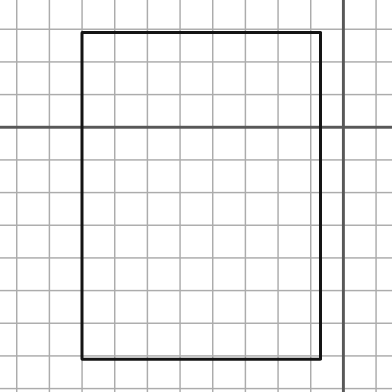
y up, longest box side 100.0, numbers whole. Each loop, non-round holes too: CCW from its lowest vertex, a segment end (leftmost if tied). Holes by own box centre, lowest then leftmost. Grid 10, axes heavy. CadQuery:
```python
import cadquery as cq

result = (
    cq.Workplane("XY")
    .moveTo(-80.0, -71.0)
    .lineTo(-7.0, -71.0)
    .lineTo(-7.0, 29.0)
    .lineTo(-80.0, 29.0)
    .close()
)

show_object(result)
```